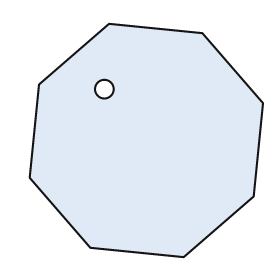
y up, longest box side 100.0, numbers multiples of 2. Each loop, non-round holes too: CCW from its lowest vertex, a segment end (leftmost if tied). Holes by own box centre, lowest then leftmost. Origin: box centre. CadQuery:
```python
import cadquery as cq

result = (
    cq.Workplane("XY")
    .moveTo(16.0, -50.0)
    .lineTo(46.0, -24.0)
    .lineTo(50.0, 16.0)
    .lineTo(24.0, 46.0)
    .lineTo(-16.0, 50.0)
    .lineTo(-46.0, 24.0)
    .lineTo(-50.0, -16.0)
    .lineTo(-24.0, -46.0)
    .close()
    .moveTo(-18.0, 22.0)
    .circle(4.0)
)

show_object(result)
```